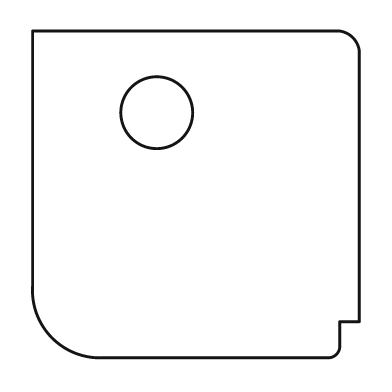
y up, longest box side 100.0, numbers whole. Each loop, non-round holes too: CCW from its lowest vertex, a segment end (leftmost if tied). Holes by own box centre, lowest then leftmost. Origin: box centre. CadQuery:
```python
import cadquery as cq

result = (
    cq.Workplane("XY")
    .moveTo(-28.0, -50.0)
    .lineTo(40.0, -50.0)
    .threePointArc((43.0, -49.0), (44.0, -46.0))
    .lineTo(44.0, -39.0)
    .lineTo(50.0, -39.0)
    .lineTo(50.0, 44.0)
    .threePointArc((48.0, 48.0), (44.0, 50.0))
    .lineTo(-50.0, 50.0)
    .lineTo(-50.0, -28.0)
    .threePointArc((-44.0, -44.0), (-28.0, -50.0))
    .close()
    .moveTo(-12.0, 25.0)
    .circle(11.0)
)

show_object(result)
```